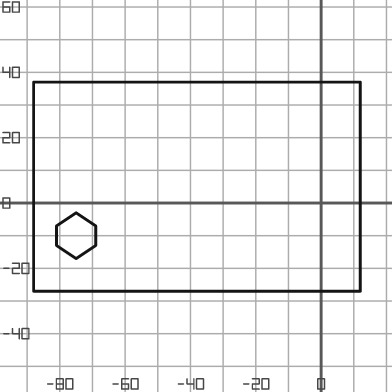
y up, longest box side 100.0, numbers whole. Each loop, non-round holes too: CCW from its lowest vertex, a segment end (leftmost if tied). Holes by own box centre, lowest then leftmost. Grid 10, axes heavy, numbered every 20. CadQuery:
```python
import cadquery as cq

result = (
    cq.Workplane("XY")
    .moveTo(-88.0, -27.0)
    .lineTo(12.0, -27.0)
    .lineTo(12.0, 37.0)
    .lineTo(-88.0, 37.0)
    .close()
    .moveTo(-75.0, -17.0)
    .lineTo(-69.0, -13.0)
    .lineTo(-69.0, -7.0)
    .lineTo(-75.0, -3.0)
    .lineTo(-81.0, -7.0)
    .lineTo(-81.0, -13.0)
    .close()
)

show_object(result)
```